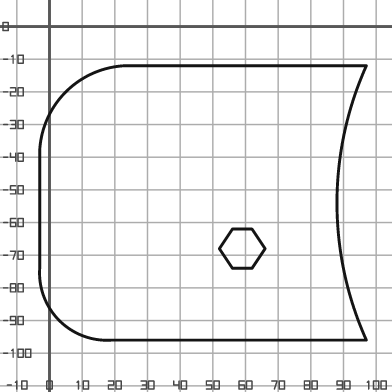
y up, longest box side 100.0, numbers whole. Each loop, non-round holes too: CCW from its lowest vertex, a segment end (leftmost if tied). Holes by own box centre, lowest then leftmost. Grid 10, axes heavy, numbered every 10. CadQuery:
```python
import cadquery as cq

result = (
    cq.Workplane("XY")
    .moveTo(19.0, -96.0)
    .lineTo(97.0, -96.0)
    .threePointArc((88.0, -54.0), (97.0, -12.0))
    .lineTo(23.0, -12.0)
    .threePointArc((5.0, -20.0), (-3.0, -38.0))
    .lineTo(-3.0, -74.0)
    .threePointArc((3.0, -90.0), (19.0, -96.0))
    .close()
    .moveTo(56.0, -74.0)
    .lineTo(62.0, -74.0)
    .lineTo(66.0, -68.0)
    .lineTo(62.0, -62.0)
    .lineTo(56.0, -62.0)
    .lineTo(52.0, -68.0)
    .close()
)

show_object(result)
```